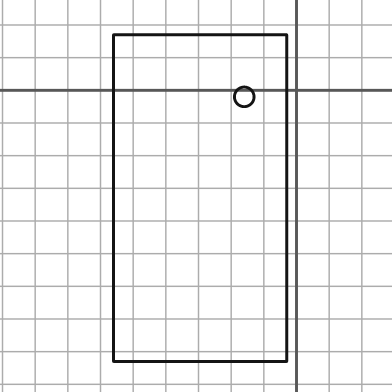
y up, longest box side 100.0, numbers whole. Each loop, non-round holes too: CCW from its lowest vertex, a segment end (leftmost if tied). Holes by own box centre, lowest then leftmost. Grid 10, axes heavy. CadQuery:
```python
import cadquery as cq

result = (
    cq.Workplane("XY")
    .moveTo(-56.0, -83.0)
    .lineTo(-3.0, -83.0)
    .lineTo(-3.0, 17.0)
    .lineTo(-56.0, 17.0)
    .close()
    .moveTo(-16.0, -2.0)
    .circle(3.0)
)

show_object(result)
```